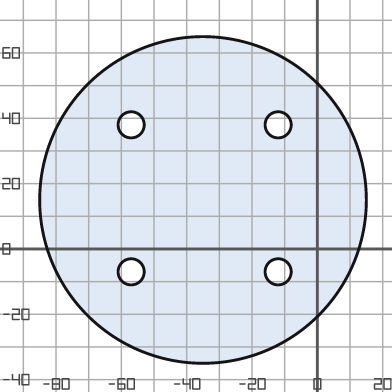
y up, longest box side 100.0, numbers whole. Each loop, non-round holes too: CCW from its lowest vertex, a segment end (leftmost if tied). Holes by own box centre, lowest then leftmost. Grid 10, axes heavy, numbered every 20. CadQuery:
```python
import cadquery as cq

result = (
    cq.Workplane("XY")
    .moveTo(-35.0, 15.0)
    .circle(50.0)
    .moveTo(-57.0, -7.0)
    .circle(4.0)
    .moveTo(-12.0, -7.0)
    .circle(4.0)
    .moveTo(-57.0, 38.0)
    .circle(4.0)
    .moveTo(-12.0, 38.0)
    .circle(4.0)
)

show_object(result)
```